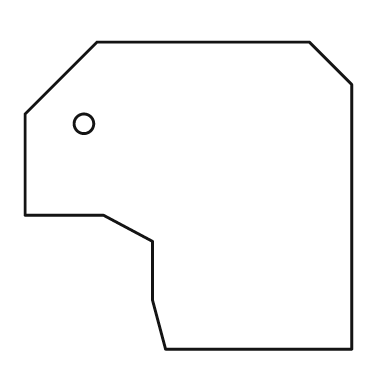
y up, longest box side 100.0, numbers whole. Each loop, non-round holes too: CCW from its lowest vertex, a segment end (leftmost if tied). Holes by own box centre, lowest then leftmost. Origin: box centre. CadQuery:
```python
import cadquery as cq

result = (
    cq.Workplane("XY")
    .moveTo(-7.0, -47.0)
    .lineTo(50.0, -47.0)
    .lineTo(50.0, 34.0)
    .lineTo(37.0, 47.0)
    .lineTo(-28.0, 47.0)
    .lineTo(-50.0, 25.0)
    .lineTo(-50.0, -6.0)
    .lineTo(-26.0, -6.0)
    .lineTo(-11.0, -14.0)
    .lineTo(-11.0, -32.0)
    .close()
    .moveTo(-32.0, 22.0)
    .circle(3.0)
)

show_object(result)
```